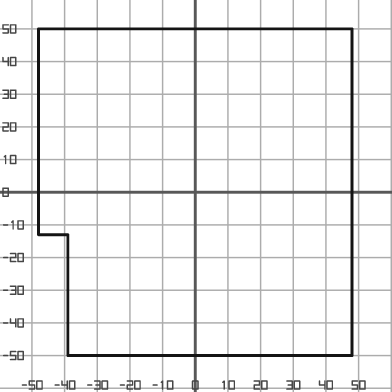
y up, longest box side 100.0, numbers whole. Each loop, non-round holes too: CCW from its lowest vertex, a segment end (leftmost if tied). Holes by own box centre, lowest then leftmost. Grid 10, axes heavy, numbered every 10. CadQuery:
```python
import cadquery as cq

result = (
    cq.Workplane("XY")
    .moveTo(-39.0, -50.0)
    .lineTo(48.0, -50.0)
    .lineTo(48.0, 50.0)
    .lineTo(-48.0, 50.0)
    .lineTo(-48.0, -13.0)
    .lineTo(-39.0, -13.0)
    .close()
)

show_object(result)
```